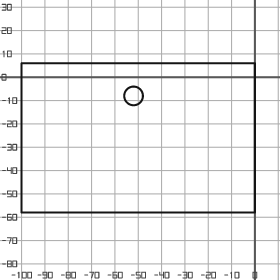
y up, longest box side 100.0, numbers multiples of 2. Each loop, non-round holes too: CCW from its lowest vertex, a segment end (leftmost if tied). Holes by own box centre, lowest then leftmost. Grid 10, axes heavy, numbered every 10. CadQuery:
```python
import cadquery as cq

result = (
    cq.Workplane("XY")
    .moveTo(-100.0, -58.0)
    .lineTo(0.0, -58.0)
    .lineTo(0.0, 6.0)
    .lineTo(-100.0, 6.0)
    .close()
    .moveTo(-52.0, -8.0)
    .circle(4.0)
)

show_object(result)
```